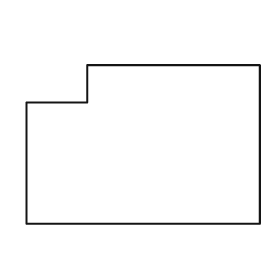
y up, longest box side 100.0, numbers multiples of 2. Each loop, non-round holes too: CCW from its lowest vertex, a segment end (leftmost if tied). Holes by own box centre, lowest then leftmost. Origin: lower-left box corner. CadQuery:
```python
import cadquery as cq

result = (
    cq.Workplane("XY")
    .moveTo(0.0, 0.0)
    .lineTo(100.0, 0.0)
    .lineTo(100.0, 68.0)
    .lineTo(26.0, 68.0)
    .lineTo(26.0, 52.0)
    .lineTo(0.0, 52.0)
    .close()
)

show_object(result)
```